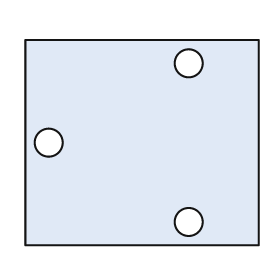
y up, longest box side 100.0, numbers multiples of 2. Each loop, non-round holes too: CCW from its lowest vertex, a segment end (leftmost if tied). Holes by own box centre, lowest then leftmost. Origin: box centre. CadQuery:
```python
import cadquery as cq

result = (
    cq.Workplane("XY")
    .moveTo(-50.0, -44.0)
    .lineTo(50.0, -44.0)
    .lineTo(50.0, 44.0)
    .lineTo(-50.0, 44.0)
    .close()
    .moveTo(20.0, -34.0)
    .circle(6.0)
    .moveTo(-40.0, 0.0)
    .circle(6.0)
    .moveTo(20.0, 34.0)
    .circle(6.0)
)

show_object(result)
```